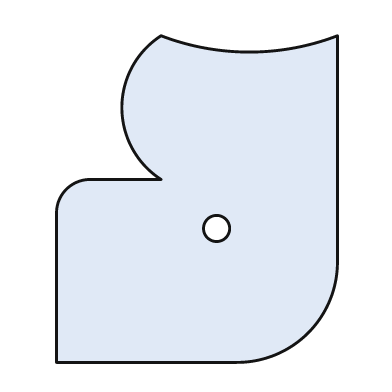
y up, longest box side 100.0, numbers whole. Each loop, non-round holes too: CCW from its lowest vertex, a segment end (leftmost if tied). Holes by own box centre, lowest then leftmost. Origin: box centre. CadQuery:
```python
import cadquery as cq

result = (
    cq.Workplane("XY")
    .moveTo(-43.0, -50.0)
    .lineTo(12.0, -50.0)
    .threePointArc((34.0, -41.0), (43.0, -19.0))
    .lineTo(43.0, 50.0)
    .threePointArc((16.0, 45.0), (-11.0, 50.0))
    .threePointArc((-23.0, 28.0), (-11.0, 6.0))
    .lineTo(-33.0, 6.0)
    .threePointArc((-40.0, 3.0), (-43.0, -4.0))
    .close()
    .moveTo(6.0, -9.0)
    .circle(4.0)
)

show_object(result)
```